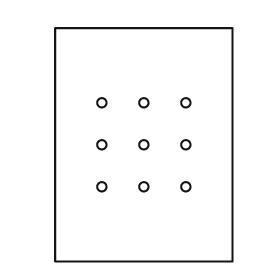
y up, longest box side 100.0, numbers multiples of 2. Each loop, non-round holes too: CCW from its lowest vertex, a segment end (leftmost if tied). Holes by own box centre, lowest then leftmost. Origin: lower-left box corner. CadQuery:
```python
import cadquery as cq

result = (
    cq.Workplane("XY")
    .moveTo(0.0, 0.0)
    .lineTo(76.0, 0.0)
    .lineTo(76.0, 100.0)
    .lineTo(0.0, 100.0)
    .close()
    .moveTo(20.0, 32.0)
    .circle(2.0)
    .moveTo(38.0, 32.0)
    .circle(2.0)
    .moveTo(56.0, 32.0)
    .circle(2.0)
    .moveTo(20.0, 50.0)
    .circle(2.0)
    .moveTo(38.0, 50.0)
    .circle(2.0)
    .moveTo(56.0, 50.0)
    .circle(2.0)
    .moveTo(20.0, 68.0)
    .circle(2.0)
    .moveTo(38.0, 68.0)
    .circle(2.0)
    .moveTo(56.0, 68.0)
    .circle(2.0)
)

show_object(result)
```